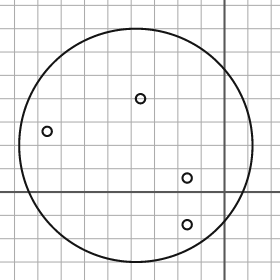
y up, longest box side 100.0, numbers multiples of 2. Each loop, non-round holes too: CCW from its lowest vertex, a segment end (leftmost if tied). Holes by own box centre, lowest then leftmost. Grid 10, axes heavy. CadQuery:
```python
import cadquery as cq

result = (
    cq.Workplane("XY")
    .moveTo(-38.0, 20.0)
    .circle(50.0)
    .moveTo(-16.0, -14.0)
    .circle(2.0)
    .moveTo(-16.0, 6.0)
    .circle(2.0)
    .moveTo(-76.0, 26.0)
    .circle(2.0)
    .moveTo(-36.0, 40.0)
    .circle(2.0)
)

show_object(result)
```